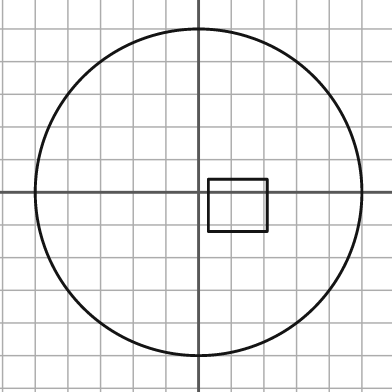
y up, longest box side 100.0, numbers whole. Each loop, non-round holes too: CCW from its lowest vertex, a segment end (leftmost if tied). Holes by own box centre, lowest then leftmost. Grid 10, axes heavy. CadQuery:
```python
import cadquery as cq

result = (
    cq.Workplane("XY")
    .moveTo(0.0, 0.0)
    .circle(50.0)
    .moveTo(3.0, -12.0)
    .lineTo(21.0, -12.0)
    .lineTo(21.0, 4.0)
    .lineTo(3.0, 4.0)
    .close()
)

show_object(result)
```